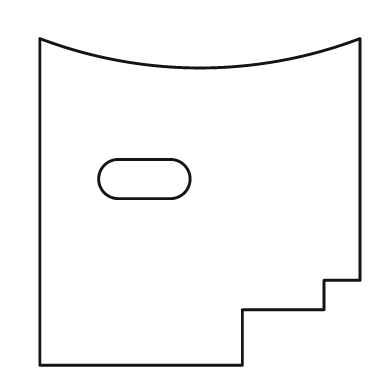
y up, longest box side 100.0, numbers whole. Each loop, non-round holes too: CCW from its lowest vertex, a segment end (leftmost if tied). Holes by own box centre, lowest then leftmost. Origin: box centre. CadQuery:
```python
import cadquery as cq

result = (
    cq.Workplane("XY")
    .moveTo(-49.0, -50.0)
    .lineTo(13.0, -50.0)
    .lineTo(13.0, -33.0)
    .lineTo(38.0, -33.0)
    .lineTo(38.0, -24.0)
    .lineTo(49.0, -24.0)
    .lineTo(49.0, 50.0)
    .threePointArc((0.0, 41.0), (-49.0, 50.0))
    .close()
    .moveTo(-25.0, 1.0)
    .lineTo(-9.0, 1.0)
    .threePointArc((-3.0, 7.0), (-9.0, 13.0))
    .lineTo(-25.0, 13.0)
    .threePointArc((-31.0, 7.0), (-25.0, 1.0))
    .close()
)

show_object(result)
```